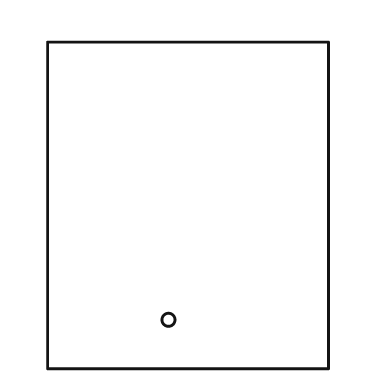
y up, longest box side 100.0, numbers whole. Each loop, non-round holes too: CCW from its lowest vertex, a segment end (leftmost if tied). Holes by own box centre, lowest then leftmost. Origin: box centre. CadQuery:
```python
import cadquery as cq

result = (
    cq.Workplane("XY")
    .moveTo(-43.0, -50.0)
    .lineTo(43.0, -50.0)
    .lineTo(43.0, 50.0)
    .lineTo(-43.0, 50.0)
    .close()
    .moveTo(-6.0, -35.0)
    .circle(2.0)
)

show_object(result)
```